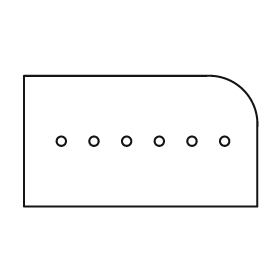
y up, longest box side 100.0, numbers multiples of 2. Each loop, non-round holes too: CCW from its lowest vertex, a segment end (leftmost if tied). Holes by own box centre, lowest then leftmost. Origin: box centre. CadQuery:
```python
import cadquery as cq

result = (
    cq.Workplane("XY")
    .moveTo(-50.0, -28.0)
    .lineTo(50.0, -28.0)
    .lineTo(50.0, 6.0)
    .threePointArc((44.0, 22.0), (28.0, 28.0))
    .lineTo(-50.0, 28.0)
    .close()
    .moveTo(-34.0, 0.0)
    .circle(2.0)
    .moveTo(-20.0, 0.0)
    .circle(2.0)
    .moveTo(-6.0, 0.0)
    .circle(2.0)
    .moveTo(8.0, 0.0)
    .circle(2.0)
    .moveTo(22.0, 0.0)
    .circle(2.0)
    .moveTo(36.0, 0.0)
    .circle(2.0)
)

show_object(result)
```